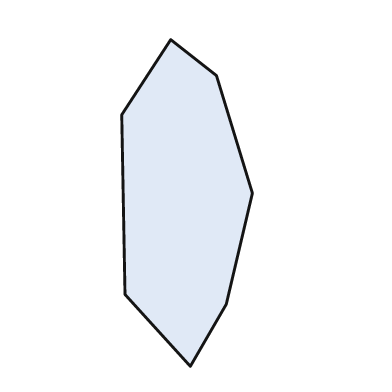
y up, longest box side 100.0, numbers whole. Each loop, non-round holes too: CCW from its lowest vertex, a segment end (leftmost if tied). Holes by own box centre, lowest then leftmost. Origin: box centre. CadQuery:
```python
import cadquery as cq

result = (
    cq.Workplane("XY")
    .moveTo(1.0, -50.0)
    .lineTo(12.0, -31.0)
    .lineTo(20.0, 3.0)
    .lineTo(9.0, 39.0)
    .lineTo(-5.0, 50.0)
    .lineTo(-20.0, 27.0)
    .lineTo(-19.0, -28.0)
    .close()
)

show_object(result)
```